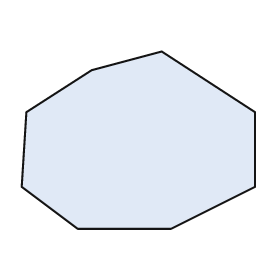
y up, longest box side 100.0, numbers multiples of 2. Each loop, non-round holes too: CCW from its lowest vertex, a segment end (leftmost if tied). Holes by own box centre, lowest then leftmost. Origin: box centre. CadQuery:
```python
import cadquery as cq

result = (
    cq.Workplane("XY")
    .moveTo(-26.0, -38.0)
    .lineTo(14.0, -38.0)
    .lineTo(50.0, -20.0)
    .lineTo(50.0, 12.0)
    .lineTo(10.0, 38.0)
    .lineTo(-20.0, 30.0)
    .lineTo(-48.0, 12.0)
    .lineTo(-50.0, -20.0)
    .close()
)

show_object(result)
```